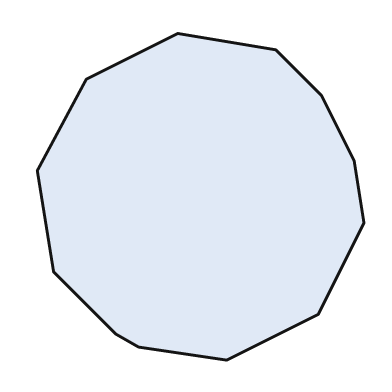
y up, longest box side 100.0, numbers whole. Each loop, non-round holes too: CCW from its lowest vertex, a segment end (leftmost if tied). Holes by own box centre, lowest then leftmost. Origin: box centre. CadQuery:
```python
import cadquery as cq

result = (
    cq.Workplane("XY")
    .moveTo(8.0, -50.0)
    .lineTo(36.0, -36.0)
    .lineTo(50.0, -8.0)
    .lineTo(47.0, 11.0)
    .lineTo(37.0, 31.0)
    .lineTo(23.0, 45.0)
    .lineTo(-7.0, 50.0)
    .lineTo(-35.0, 36.0)
    .lineTo(-50.0, 8.0)
    .lineTo(-45.0, -23.0)
    .lineTo(-26.0, -42.0)
    .lineTo(-19.0, -46.0)
    .close()
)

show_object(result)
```